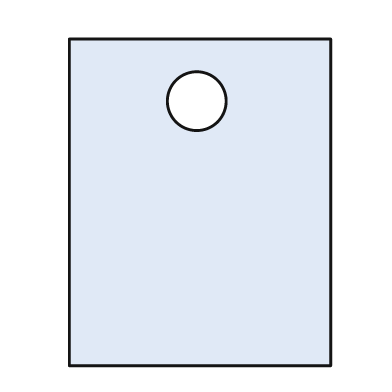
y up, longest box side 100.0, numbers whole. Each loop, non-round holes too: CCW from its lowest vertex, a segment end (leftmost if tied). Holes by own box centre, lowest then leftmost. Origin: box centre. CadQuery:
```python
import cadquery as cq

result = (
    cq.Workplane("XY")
    .moveTo(-40.0, -50.0)
    .lineTo(40.0, -50.0)
    .lineTo(40.0, 50.0)
    .lineTo(-40.0, 50.0)
    .close()
    .moveTo(-1.0, 31.0)
    .circle(9.0)
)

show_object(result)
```